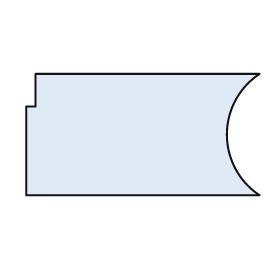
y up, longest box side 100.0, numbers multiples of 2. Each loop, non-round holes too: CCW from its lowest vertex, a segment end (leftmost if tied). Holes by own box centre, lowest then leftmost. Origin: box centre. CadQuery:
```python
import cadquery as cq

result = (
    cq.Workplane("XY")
    .moveTo(-50.0, -26.0)
    .lineTo(50.0, -26.0)
    .threePointArc((36.0, 0.0), (50.0, 26.0))
    .lineTo(-46.0, 26.0)
    .lineTo(-46.0, 12.0)
    .lineTo(-50.0, 12.0)
    .close()
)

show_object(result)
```